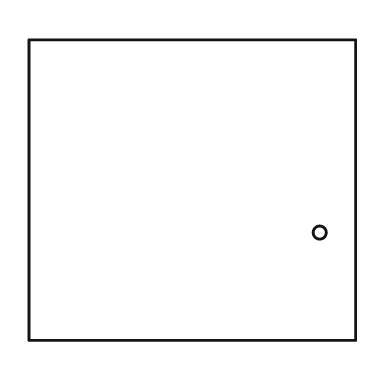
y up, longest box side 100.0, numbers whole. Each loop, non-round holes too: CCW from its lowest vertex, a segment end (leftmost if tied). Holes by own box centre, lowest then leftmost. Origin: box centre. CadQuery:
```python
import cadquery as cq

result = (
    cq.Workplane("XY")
    .moveTo(-50.0, -46.0)
    .lineTo(50.0, -46.0)
    .lineTo(50.0, 46.0)
    .lineTo(-50.0, 46.0)
    .close()
    .moveTo(39.0, -13.0)
    .circle(2.0)
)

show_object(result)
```